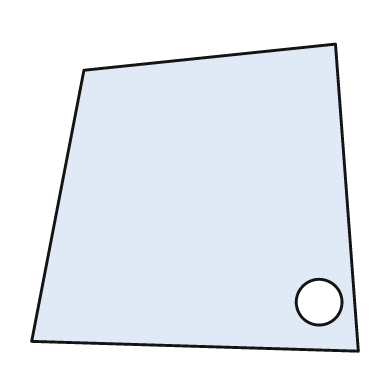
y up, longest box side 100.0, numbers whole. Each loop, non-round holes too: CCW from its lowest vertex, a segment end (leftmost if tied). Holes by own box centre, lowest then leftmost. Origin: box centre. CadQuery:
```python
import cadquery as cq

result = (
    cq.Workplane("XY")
    .moveTo(50.0, -47.0)
    .lineTo(43.0, 47.0)
    .lineTo(-34.0, 39.0)
    .lineTo(-50.0, -44.0)
    .close()
    .moveTo(38.0, -32.0)
    .circle(7.0)
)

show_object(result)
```